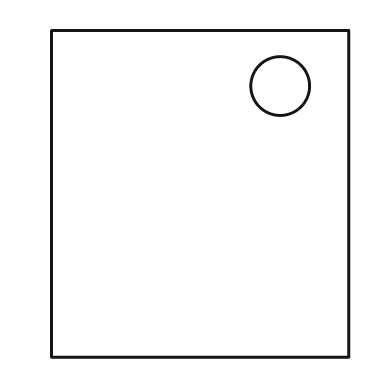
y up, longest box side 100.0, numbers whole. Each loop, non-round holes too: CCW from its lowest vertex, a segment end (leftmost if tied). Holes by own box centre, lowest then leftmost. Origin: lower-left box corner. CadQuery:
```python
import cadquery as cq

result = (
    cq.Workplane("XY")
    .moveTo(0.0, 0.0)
    .lineTo(91.0, 0.0)
    .lineTo(91.0, 100.0)
    .lineTo(0.0, 100.0)
    .close()
    .moveTo(70.0, 83.0)
    .circle(9.0)
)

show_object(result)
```